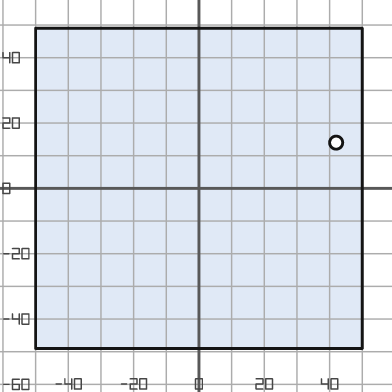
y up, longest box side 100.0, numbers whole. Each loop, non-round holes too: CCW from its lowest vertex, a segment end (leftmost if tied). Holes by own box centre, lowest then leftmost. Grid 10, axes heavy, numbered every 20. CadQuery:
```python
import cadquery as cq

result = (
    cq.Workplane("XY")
    .moveTo(-50.0, -49.0)
    .lineTo(50.0, -49.0)
    .lineTo(50.0, 49.0)
    .lineTo(-50.0, 49.0)
    .close()
    .moveTo(42.0, 14.0)
    .circle(2.0)
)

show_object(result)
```